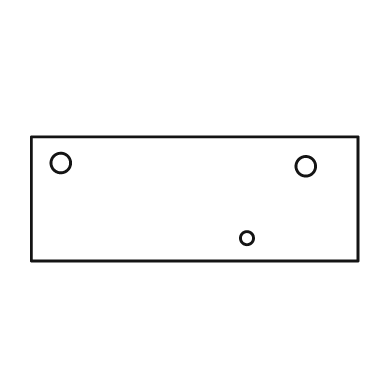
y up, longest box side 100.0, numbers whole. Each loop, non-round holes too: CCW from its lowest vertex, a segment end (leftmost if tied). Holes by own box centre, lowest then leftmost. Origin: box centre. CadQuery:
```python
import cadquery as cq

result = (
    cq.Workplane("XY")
    .moveTo(-50.0, -19.0)
    .lineTo(50.0, -19.0)
    .lineTo(50.0, 19.0)
    .lineTo(-50.0, 19.0)
    .close()
    .moveTo(16.0, -12.0)
    .circle(2.0)
    .moveTo(34.0, 10.0)
    .circle(3.0)
    .moveTo(-41.0, 11.0)
    .circle(3.0)
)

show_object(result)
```